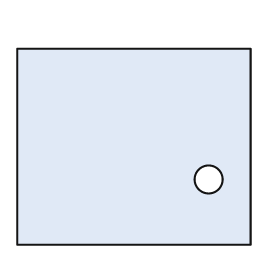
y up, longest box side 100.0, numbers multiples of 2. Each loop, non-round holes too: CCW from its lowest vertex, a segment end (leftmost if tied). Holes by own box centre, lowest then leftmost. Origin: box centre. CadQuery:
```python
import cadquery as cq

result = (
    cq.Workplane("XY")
    .moveTo(-50.0, -42.0)
    .lineTo(50.0, -42.0)
    .lineTo(50.0, 42.0)
    .lineTo(-50.0, 42.0)
    .close()
    .moveTo(32.0, -14.0)
    .circle(6.0)
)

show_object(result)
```